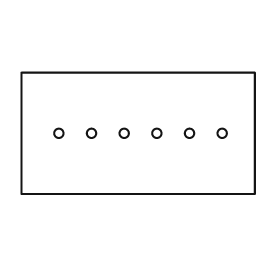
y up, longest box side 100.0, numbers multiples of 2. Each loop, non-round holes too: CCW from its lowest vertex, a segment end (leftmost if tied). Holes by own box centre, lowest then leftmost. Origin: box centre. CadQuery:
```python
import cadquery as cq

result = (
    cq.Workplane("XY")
    .moveTo(-50.0, -26.0)
    .lineTo(50.0, -26.0)
    .lineTo(50.0, 26.0)
    .lineTo(-50.0, 26.0)
    .close()
    .moveTo(-34.0, 0.0)
    .circle(2.0)
    .moveTo(-20.0, 0.0)
    .circle(2.0)
    .moveTo(-6.0, 0.0)
    .circle(2.0)
    .moveTo(8.0, 0.0)
    .circle(2.0)
    .moveTo(22.0, 0.0)
    .circle(2.0)
    .moveTo(36.0, 0.0)
    .circle(2.0)
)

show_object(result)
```